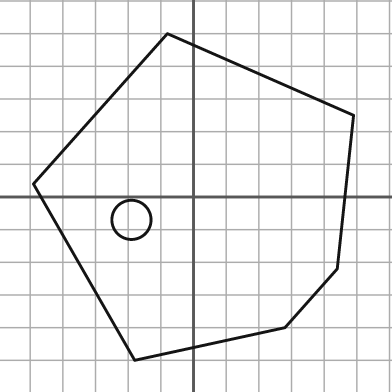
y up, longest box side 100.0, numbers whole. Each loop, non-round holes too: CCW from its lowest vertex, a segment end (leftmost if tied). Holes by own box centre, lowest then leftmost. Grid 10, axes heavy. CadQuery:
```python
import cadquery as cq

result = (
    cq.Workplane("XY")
    .moveTo(-18.0, -50.0)
    .lineTo(28.0, -40.0)
    .lineTo(44.0, -22.0)
    .lineTo(49.0, 25.0)
    .lineTo(-8.0, 50.0)
    .lineTo(-49.0, 4.0)
    .close()
    .moveTo(-19.0, -7.0)
    .circle(6.0)
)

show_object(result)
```